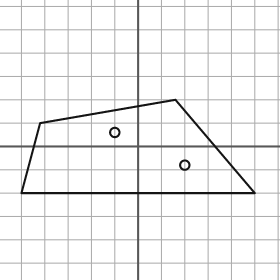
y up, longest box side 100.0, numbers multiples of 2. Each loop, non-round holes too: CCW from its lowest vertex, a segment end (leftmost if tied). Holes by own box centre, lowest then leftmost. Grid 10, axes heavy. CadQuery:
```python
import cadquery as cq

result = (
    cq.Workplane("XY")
    .moveTo(-50.0, -20.0)
    .lineTo(50.0, -20.0)
    .lineTo(16.0, 20.0)
    .lineTo(-42.0, 10.0)
    .close()
    .moveTo(20.0, -8.0)
    .circle(2.0)
    .moveTo(-10.0, 6.0)
    .circle(2.0)
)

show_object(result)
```